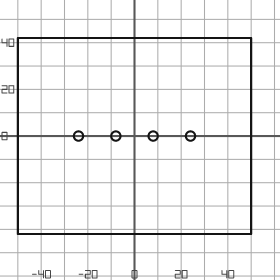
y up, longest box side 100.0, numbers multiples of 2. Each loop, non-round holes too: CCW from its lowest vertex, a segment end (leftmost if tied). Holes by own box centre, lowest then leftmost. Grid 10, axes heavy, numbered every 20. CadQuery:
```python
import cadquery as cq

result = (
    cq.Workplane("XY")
    .moveTo(-50.0, -42.0)
    .lineTo(50.0, -42.0)
    .lineTo(50.0, 42.0)
    .lineTo(-50.0, 42.0)
    .close()
    .moveTo(-24.0, 0.0)
    .circle(2.0)
    .moveTo(-8.0, 0.0)
    .circle(2.0)
    .moveTo(8.0, 0.0)
    .circle(2.0)
    .moveTo(24.0, 0.0)
    .circle(2.0)
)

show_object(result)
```